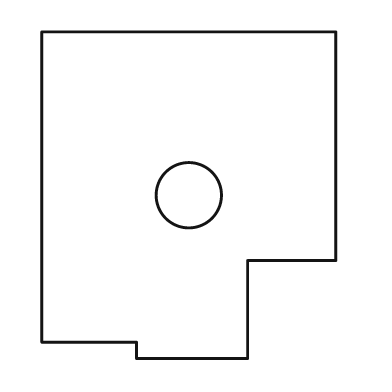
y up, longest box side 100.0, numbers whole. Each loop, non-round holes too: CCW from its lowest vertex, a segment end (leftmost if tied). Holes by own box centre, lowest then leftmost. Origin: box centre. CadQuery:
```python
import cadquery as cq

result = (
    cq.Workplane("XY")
    .moveTo(-16.0, -50.0)
    .lineTo(18.0, -50.0)
    .lineTo(18.0, -20.0)
    .lineTo(45.0, -20.0)
    .lineTo(45.0, 50.0)
    .lineTo(-45.0, 50.0)
    .lineTo(-45.0, -45.0)
    .lineTo(-16.0, -45.0)
    .close()
    .moveTo(0.0, 0.0)
    .circle(10.0)
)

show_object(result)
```